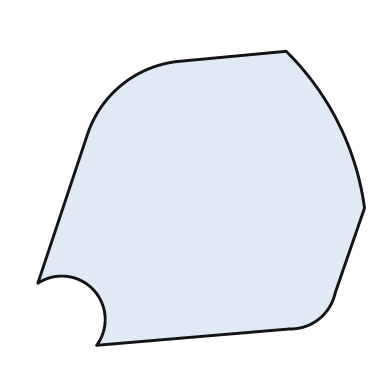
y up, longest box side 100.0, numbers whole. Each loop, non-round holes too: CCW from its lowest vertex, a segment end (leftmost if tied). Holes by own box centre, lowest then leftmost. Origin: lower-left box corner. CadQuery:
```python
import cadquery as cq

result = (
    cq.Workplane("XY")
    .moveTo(18.0, 0.0)
    .lineTo(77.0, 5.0)
    .threePointArc((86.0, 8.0), (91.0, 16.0))
    .lineTo(100.0, 42.0)
    .threePointArc((92.0, 68.0), (76.0, 90.0))
    .lineTo(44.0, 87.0)
    .threePointArc((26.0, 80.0), (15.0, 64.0))
    .lineTo(0.0, 19.0)
    .threePointArc((17.0, 17.0), (18.0, 0.0))
    .close()
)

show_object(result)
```